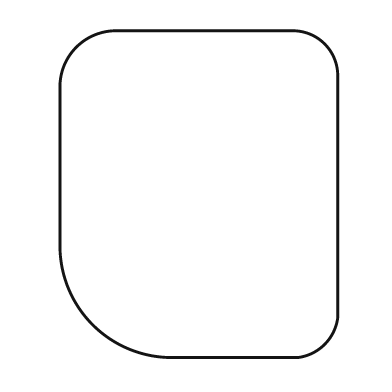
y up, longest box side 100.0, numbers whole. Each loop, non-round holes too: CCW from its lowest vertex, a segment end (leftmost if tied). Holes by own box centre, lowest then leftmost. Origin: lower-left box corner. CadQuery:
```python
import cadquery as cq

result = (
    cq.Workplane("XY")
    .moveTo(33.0, 0.0)
    .lineTo(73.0, 0.0)
    .threePointArc((81.0, 4.0), (85.0, 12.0))
    .lineTo(85.0, 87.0)
    .threePointArc((81.0, 96.0), (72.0, 100.0))
    .lineTo(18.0, 100.0)
    .threePointArc((5.0, 95.0), (0.0, 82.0))
    .lineTo(0.0, 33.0)
    .threePointArc((10.0, 10.0), (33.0, 0.0))
    .close()
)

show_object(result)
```